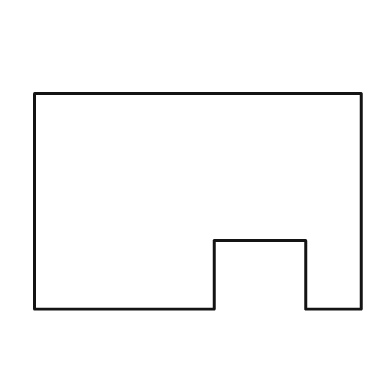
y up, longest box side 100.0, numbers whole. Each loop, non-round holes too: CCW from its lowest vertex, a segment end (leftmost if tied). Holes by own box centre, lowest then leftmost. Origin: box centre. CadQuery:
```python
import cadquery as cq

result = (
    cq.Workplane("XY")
    .moveTo(-50.0, -33.0)
    .lineTo(5.0, -33.0)
    .lineTo(5.0, -12.0)
    .lineTo(33.0, -12.0)
    .lineTo(33.0, -33.0)
    .lineTo(50.0, -33.0)
    .lineTo(50.0, 33.0)
    .lineTo(-50.0, 33.0)
    .close()
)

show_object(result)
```